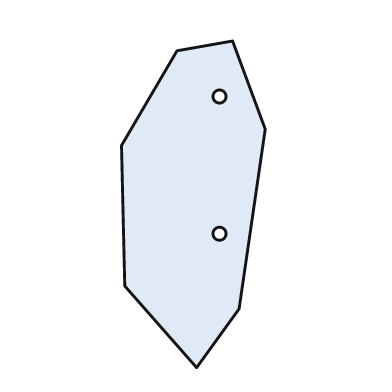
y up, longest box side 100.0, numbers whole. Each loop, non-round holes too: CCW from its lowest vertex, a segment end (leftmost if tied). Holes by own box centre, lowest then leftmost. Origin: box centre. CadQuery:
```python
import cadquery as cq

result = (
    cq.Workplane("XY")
    .moveTo(1.0, -50.0)
    .lineTo(14.0, -32.0)
    .lineTo(22.0, 23.0)
    .lineTo(12.0, 50.0)
    .lineTo(-5.0, 47.0)
    .lineTo(-22.0, 18.0)
    .lineTo(-21.0, -25.0)
    .close()
    .moveTo(8.0, -9.0)
    .circle(2.0)
    .moveTo(8.0, 33.0)
    .circle(2.0)
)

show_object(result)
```